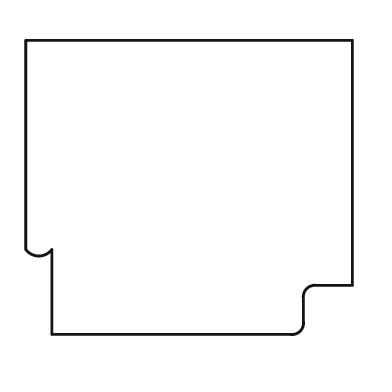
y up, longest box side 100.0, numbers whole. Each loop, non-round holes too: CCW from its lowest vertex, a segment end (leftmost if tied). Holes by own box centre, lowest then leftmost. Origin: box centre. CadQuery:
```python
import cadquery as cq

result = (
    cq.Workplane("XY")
    .moveTo(-42.0, -45.0)
    .lineTo(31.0, -45.0)
    .threePointArc((34.0, -44.0), (35.0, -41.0))
    .lineTo(35.0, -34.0)
    .threePointArc((36.0, -31.0), (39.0, -30.0))
    .lineTo(50.0, -30.0)
    .lineTo(50.0, 45.0)
    .lineTo(-50.0, 45.0)
    .lineTo(-50.0, -19.0)
    .threePointArc((-46.0, -21.0), (-42.0, -19.0))
    .close()
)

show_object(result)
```